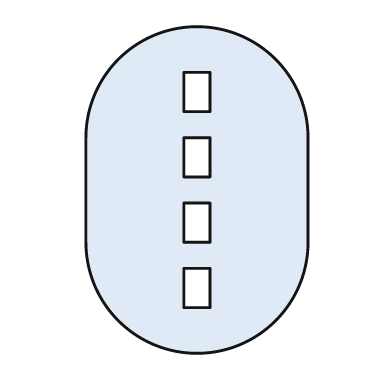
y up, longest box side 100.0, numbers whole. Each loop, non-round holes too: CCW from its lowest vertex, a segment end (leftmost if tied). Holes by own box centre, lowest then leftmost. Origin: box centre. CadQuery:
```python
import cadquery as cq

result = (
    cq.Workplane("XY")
    .moveTo(-34.0, -16.0)
    .threePointArc((0.0, -50.0), (34.0, -16.0))
    .lineTo(34.0, 16.0)
    .threePointArc((0.0, 50.0), (-34.0, 16.0))
    .close()
    .moveTo(-4.0, -36.0)
    .lineTo(4.0, -36.0)
    .lineTo(4.0, -24.0)
    .lineTo(-4.0, -24.0)
    .close()
    .moveTo(-4.0, -16.0)
    .lineTo(4.0, -16.0)
    .lineTo(4.0, -4.0)
    .lineTo(-4.0, -4.0)
    .close()
    .moveTo(-4.0, 4.0)
    .lineTo(4.0, 4.0)
    .lineTo(4.0, 16.0)
    .lineTo(-4.0, 16.0)
    .close()
    .moveTo(-4.0, 24.0)
    .lineTo(4.0, 24.0)
    .lineTo(4.0, 36.0)
    .lineTo(-4.0, 36.0)
    .close()
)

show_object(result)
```